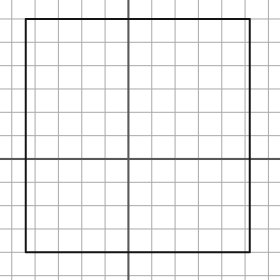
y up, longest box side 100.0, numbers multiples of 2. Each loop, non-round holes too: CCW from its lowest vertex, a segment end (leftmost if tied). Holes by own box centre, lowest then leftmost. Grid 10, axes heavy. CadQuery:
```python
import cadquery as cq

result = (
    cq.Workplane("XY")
    .moveTo(-44.0, -40.0)
    .lineTo(52.0, -40.0)
    .lineTo(52.0, 60.0)
    .lineTo(-44.0, 60.0)
    .close()
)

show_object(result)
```